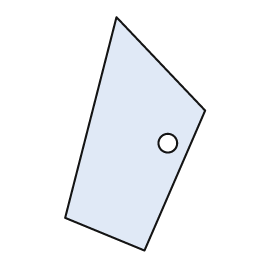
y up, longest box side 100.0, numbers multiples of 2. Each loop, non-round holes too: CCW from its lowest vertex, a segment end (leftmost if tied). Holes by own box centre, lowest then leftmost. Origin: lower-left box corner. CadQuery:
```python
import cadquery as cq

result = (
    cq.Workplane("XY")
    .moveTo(34.0, 0.0)
    .lineTo(60.0, 60.0)
    .lineTo(22.0, 100.0)
    .lineTo(0.0, 14.0)
    .close()
    .moveTo(44.0, 46.0)
    .circle(4.0)
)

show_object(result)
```